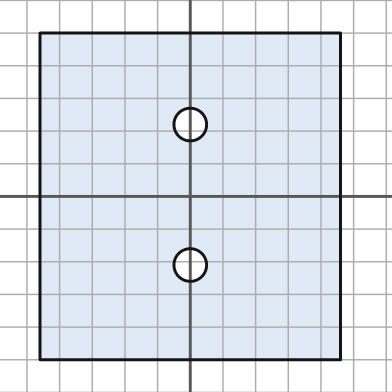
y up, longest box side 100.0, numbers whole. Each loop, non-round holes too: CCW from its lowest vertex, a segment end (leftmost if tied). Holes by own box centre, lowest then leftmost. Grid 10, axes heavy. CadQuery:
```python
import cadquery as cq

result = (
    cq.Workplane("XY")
    .moveTo(-46.0, -50.0)
    .lineTo(46.0, -50.0)
    .lineTo(46.0, 50.0)
    .lineTo(-46.0, 50.0)
    .close()
    .moveTo(0.0, -21.0)
    .circle(5.0)
    .moveTo(0.0, 22.0)
    .circle(5.0)
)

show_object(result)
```